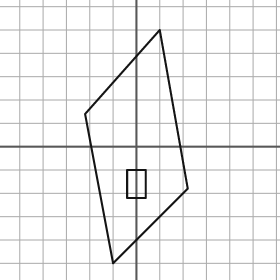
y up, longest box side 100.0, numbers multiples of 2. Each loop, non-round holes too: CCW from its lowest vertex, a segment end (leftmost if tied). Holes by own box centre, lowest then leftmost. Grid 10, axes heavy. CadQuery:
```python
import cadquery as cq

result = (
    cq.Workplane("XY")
    .moveTo(-10.0, -50.0)
    .lineTo(22.0, -18.0)
    .lineTo(10.0, 50.0)
    .lineTo(-22.0, 14.0)
    .close()
    .moveTo(-4.0, -22.0)
    .lineTo(4.0, -22.0)
    .lineTo(4.0, -10.0)
    .lineTo(-4.0, -10.0)
    .close()
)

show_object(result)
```